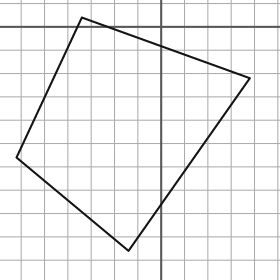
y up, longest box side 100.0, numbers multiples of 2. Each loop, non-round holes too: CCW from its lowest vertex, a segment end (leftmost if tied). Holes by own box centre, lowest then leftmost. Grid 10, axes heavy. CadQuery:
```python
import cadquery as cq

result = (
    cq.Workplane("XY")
    .moveTo(-14.0, -96.0)
    .lineTo(38.0, -22.0)
    .lineTo(-34.0, 4.0)
    .lineTo(-62.0, -56.0)
    .close()
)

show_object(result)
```